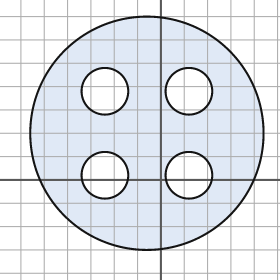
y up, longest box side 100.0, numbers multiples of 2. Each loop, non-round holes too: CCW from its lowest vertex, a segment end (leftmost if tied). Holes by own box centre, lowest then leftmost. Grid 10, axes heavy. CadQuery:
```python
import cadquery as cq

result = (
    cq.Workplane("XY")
    .moveTo(-6.0, 20.0)
    .circle(50.0)
    .moveTo(-24.0, 2.0)
    .circle(10.0)
    .moveTo(12.0, 2.0)
    .circle(10.0)
    .moveTo(-24.0, 38.0)
    .circle(10.0)
    .moveTo(12.0, 38.0)
    .circle(10.0)
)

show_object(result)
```